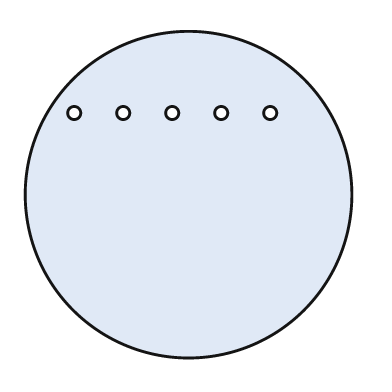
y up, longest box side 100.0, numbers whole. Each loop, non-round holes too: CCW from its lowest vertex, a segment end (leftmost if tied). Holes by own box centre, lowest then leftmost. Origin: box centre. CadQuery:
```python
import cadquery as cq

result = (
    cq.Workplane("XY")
    .moveTo(0.0, 0.0)
    .circle(50.0)
    .moveTo(-35.0, 25.0)
    .circle(2.0)
    .moveTo(-20.0, 25.0)
    .circle(2.0)
    .moveTo(-5.0, 25.0)
    .circle(2.0)
    .moveTo(10.0, 25.0)
    .circle(2.0)
    .moveTo(25.0, 25.0)
    .circle(2.0)
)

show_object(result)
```